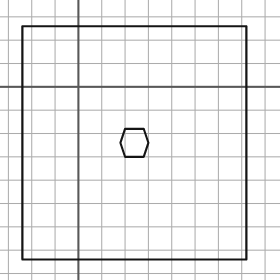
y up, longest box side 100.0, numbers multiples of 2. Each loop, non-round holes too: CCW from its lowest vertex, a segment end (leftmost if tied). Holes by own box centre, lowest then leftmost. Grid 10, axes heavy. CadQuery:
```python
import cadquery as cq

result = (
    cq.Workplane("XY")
    .moveTo(-24.0, -74.0)
    .lineTo(72.0, -74.0)
    .lineTo(72.0, 26.0)
    .lineTo(-24.0, 26.0)
    .close()
    .moveTo(20.0, -30.0)
    .lineTo(28.0, -30.0)
    .lineTo(30.0, -24.0)
    .lineTo(28.0, -18.0)
    .lineTo(20.0, -18.0)
    .lineTo(18.0, -24.0)
    .close()
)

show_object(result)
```